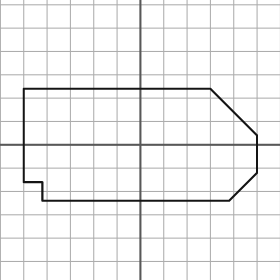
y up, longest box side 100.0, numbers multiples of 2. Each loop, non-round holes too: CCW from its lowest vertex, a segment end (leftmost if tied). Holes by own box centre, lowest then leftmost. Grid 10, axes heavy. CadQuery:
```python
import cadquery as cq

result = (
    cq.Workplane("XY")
    .moveTo(-42.0, -24.0)
    .lineTo(38.0, -24.0)
    .lineTo(50.0, -12.0)
    .lineTo(50.0, 4.0)
    .lineTo(30.0, 24.0)
    .lineTo(-50.0, 24.0)
    .lineTo(-50.0, -16.0)
    .lineTo(-42.0, -16.0)
    .close()
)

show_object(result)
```